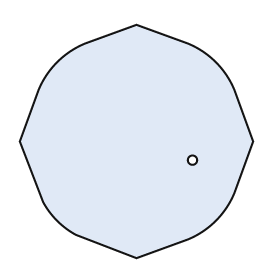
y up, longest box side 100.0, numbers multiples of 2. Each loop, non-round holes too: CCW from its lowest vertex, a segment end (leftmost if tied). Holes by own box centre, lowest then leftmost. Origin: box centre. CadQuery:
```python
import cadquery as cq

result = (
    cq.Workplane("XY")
    .moveTo(0.0, -50.0)
    .lineTo(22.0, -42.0)
    .threePointArc((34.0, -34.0), (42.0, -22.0))
    .lineTo(50.0, 0.0)
    .lineTo(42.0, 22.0)
    .threePointArc((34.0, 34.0), (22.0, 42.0))
    .lineTo(0.0, 50.0)
    .lineTo(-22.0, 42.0)
    .threePointArc((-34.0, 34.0), (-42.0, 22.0))
    .lineTo(-50.0, 0.0)
    .lineTo(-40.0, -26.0)
    .threePointArc((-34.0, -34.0), (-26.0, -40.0))
    .close()
    .moveTo(24.0, -8.0)
    .circle(2.0)
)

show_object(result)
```